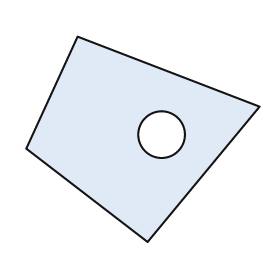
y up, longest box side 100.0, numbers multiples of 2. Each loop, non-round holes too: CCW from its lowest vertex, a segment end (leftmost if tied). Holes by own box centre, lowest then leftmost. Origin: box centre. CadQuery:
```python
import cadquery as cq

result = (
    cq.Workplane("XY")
    .moveTo(2.0, -44.0)
    .lineTo(50.0, 14.0)
    .lineTo(-28.0, 44.0)
    .lineTo(-50.0, -4.0)
    .close()
    .moveTo(8.0, 2.0)
    .circle(10.0)
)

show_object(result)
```